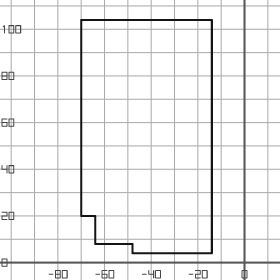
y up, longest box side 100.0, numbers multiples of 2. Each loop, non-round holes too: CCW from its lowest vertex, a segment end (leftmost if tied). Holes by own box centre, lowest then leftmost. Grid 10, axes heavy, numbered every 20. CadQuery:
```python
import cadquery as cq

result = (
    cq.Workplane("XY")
    .moveTo(-48.0, 4.0)
    .lineTo(-14.0, 4.0)
    .lineTo(-14.0, 104.0)
    .lineTo(-70.0, 104.0)
    .lineTo(-70.0, 20.0)
    .lineTo(-64.0, 20.0)
    .lineTo(-64.0, 8.0)
    .lineTo(-48.0, 8.0)
    .close()
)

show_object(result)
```